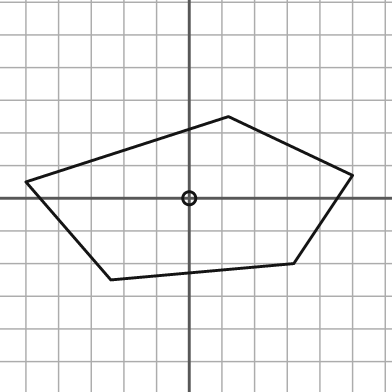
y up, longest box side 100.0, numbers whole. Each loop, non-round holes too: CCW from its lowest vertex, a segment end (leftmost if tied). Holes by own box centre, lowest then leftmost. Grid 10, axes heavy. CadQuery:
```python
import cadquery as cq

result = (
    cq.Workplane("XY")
    .moveTo(-24.0, -25.0)
    .lineTo(32.0, -20.0)
    .lineTo(50.0, 7.0)
    .lineTo(12.0, 25.0)
    .lineTo(-50.0, 5.0)
    .close()
    .moveTo(0.0, 0.0)
    .circle(2.0)
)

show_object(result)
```